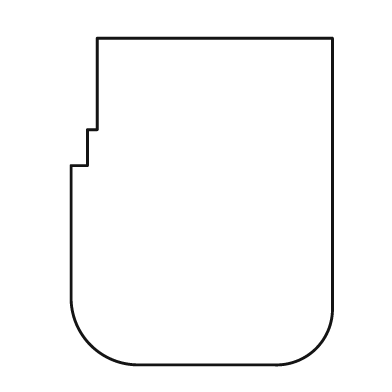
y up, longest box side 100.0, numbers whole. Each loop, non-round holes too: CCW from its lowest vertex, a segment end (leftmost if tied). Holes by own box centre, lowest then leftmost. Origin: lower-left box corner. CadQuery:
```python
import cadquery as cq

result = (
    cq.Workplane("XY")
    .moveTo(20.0, 0.0)
    .lineTo(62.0, 0.0)
    .threePointArc((75.0, 5.0), (80.0, 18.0))
    .lineTo(80.0, 100.0)
    .lineTo(8.0, 100.0)
    .lineTo(8.0, 72.0)
    .lineTo(5.0, 72.0)
    .lineTo(5.0, 61.0)
    .lineTo(0.0, 61.0)
    .lineTo(0.0, 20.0)
    .threePointArc((6.0, 6.0), (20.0, 0.0))
    .close()
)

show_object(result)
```